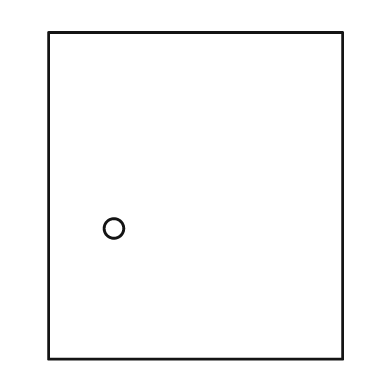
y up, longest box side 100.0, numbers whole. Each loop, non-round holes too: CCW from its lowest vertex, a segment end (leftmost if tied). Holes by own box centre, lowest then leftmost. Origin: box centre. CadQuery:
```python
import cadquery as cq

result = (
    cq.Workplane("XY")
    .moveTo(-45.0, -50.0)
    .lineTo(45.0, -50.0)
    .lineTo(45.0, 50.0)
    .lineTo(-45.0, 50.0)
    .close()
    .moveTo(-25.0, -10.0)
    .circle(3.0)
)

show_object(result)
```